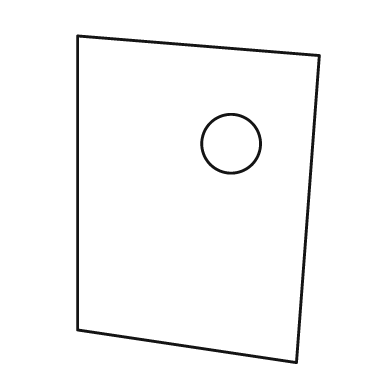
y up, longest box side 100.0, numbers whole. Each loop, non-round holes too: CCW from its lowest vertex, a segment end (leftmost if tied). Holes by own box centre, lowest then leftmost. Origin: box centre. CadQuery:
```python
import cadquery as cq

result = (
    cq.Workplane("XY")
    .moveTo(30.0, -50.0)
    .lineTo(37.0, 44.0)
    .lineTo(-37.0, 50.0)
    .lineTo(-37.0, -40.0)
    .close()
    .moveTo(10.0, 17.0)
    .circle(9.0)
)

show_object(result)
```